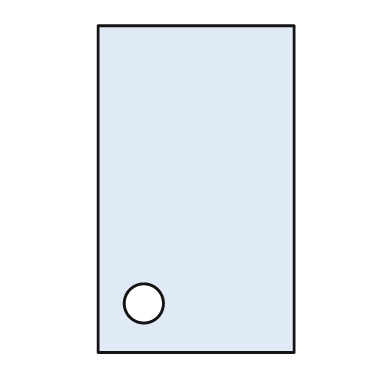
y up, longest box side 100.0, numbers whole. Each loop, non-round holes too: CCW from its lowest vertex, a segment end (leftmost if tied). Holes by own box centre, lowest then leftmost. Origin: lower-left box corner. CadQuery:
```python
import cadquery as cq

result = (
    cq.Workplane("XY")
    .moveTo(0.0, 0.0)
    .lineTo(60.0, 0.0)
    .lineTo(60.0, 100.0)
    .lineTo(0.0, 100.0)
    .close()
    .moveTo(14.0, 15.0)
    .circle(6.0)
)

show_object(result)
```